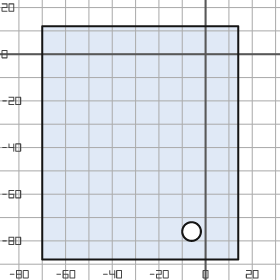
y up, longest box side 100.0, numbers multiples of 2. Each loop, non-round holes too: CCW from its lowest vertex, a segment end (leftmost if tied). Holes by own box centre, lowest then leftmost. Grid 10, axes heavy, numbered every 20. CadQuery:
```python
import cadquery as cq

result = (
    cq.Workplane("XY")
    .moveTo(-70.0, -88.0)
    .lineTo(14.0, -88.0)
    .lineTo(14.0, 12.0)
    .lineTo(-70.0, 12.0)
    .close()
    .moveTo(-6.0, -76.0)
    .circle(4.0)
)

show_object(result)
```